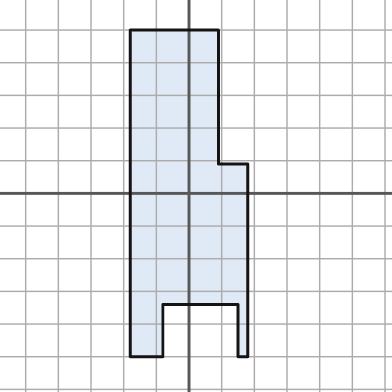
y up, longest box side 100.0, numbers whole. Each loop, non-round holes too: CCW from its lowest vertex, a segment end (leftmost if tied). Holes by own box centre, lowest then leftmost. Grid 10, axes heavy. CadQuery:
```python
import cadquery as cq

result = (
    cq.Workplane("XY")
    .moveTo(-18.0, -50.0)
    .lineTo(-8.0, -50.0)
    .lineTo(-8.0, -34.0)
    .lineTo(15.0, -34.0)
    .lineTo(15.0, -50.0)
    .lineTo(18.0, -50.0)
    .lineTo(18.0, 9.0)
    .lineTo(9.0, 9.0)
    .lineTo(9.0, 50.0)
    .lineTo(-18.0, 50.0)
    .close()
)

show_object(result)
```